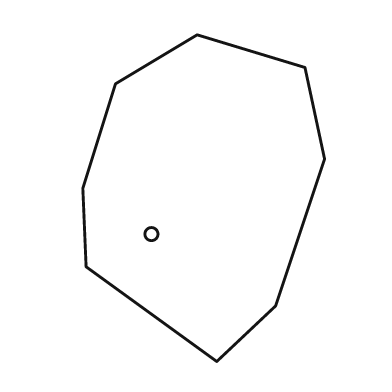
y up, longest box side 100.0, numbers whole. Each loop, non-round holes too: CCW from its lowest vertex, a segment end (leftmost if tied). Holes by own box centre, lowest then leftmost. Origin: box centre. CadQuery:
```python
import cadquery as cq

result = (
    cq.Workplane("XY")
    .moveTo(4.0, -50.0)
    .lineTo(22.0, -33.0)
    .lineTo(37.0, 12.0)
    .lineTo(31.0, 40.0)
    .lineTo(-2.0, 50.0)
    .lineTo(-27.0, 35.0)
    .lineTo(-37.0, 3.0)
    .lineTo(-36.0, -21.0)
    .close()
    .moveTo(-16.0, -11.0)
    .circle(2.0)
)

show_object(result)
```